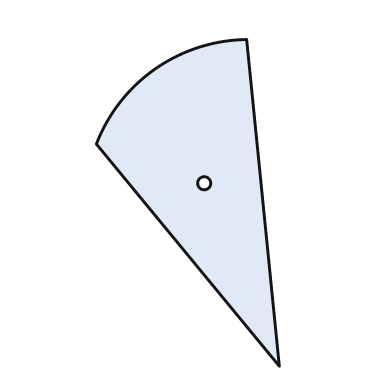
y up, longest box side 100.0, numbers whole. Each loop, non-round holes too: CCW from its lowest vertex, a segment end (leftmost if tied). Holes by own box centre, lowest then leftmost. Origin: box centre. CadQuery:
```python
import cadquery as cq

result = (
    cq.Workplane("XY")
    .moveTo(28.0, -50.0)
    .lineTo(18.0, 50.0)
    .threePointArc((-10.0, 41.0), (-28.0, 18.0))
    .close()
    .moveTo(5.0, 6.0)
    .circle(2.0)
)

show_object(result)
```